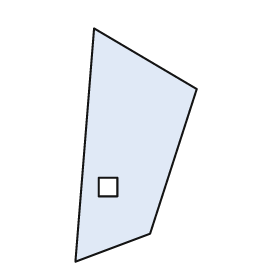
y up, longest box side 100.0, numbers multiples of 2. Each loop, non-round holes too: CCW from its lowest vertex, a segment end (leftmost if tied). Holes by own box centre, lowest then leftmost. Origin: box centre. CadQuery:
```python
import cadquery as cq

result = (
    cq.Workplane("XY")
    .moveTo(-26.0, -50.0)
    .lineTo(6.0, -38.0)
    .lineTo(26.0, 24.0)
    .lineTo(-18.0, 50.0)
    .close()
    .moveTo(-16.0, -22.0)
    .lineTo(-8.0, -22.0)
    .lineTo(-8.0, -14.0)
    .lineTo(-16.0, -14.0)
    .close()
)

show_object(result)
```